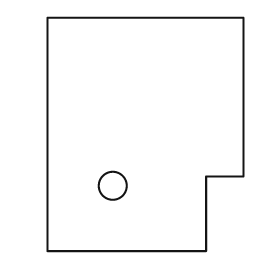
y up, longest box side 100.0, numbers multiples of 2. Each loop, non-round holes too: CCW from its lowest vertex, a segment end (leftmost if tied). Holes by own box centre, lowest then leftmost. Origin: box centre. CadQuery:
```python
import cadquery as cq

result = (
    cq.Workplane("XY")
    .moveTo(-42.0, -50.0)
    .lineTo(26.0, -50.0)
    .lineTo(26.0, -18.0)
    .lineTo(42.0, -18.0)
    .lineTo(42.0, 50.0)
    .lineTo(-42.0, 50.0)
    .close()
    .moveTo(-14.0, -22.0)
    .circle(6.0)
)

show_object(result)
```